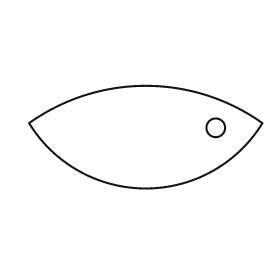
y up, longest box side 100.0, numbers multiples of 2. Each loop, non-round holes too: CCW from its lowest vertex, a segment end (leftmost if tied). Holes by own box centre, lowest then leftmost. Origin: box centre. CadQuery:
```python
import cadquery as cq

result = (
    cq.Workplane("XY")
    .moveTo(-50.0, 6.0)
    .threePointArc((0.0, -22.0), (50.0, 6.0))
    .threePointArc((0.0, 22.0), (-50.0, 6.0))
    .close()
    .moveTo(30.0, 4.0)
    .circle(4.0)
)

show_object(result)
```